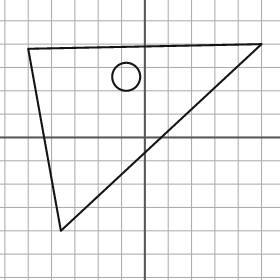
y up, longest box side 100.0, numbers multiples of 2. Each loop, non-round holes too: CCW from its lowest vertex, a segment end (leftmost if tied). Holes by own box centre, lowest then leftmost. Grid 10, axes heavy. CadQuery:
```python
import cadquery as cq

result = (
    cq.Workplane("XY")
    .moveTo(-36.0, -40.0)
    .lineTo(50.0, 40.0)
    .lineTo(-50.0, 38.0)
    .close()
    .moveTo(-8.0, 26.0)
    .circle(6.0)
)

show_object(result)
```